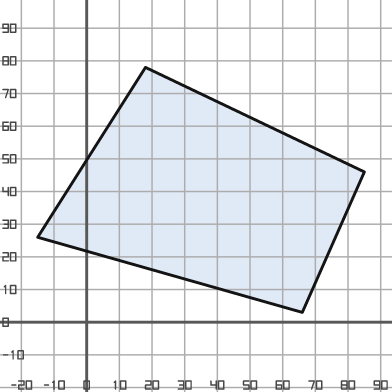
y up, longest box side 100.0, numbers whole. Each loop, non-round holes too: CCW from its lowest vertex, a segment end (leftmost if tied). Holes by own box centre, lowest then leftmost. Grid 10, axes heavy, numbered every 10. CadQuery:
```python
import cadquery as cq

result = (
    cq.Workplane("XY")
    .moveTo(66.0, 3.0)
    .lineTo(85.0, 46.0)
    .lineTo(18.0, 78.0)
    .lineTo(-15.0, 26.0)
    .close()
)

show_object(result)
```